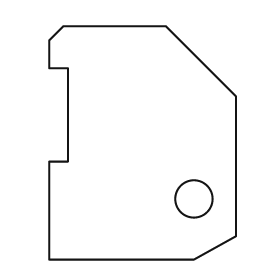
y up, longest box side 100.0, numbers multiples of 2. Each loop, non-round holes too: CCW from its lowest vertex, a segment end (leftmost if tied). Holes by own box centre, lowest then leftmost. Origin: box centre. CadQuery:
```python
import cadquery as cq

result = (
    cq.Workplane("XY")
    .moveTo(-40.0, -50.0)
    .lineTo(22.0, -50.0)
    .lineTo(40.0, -40.0)
    .lineTo(40.0, 20.0)
    .lineTo(10.0, 50.0)
    .lineTo(-34.0, 50.0)
    .lineTo(-40.0, 44.0)
    .lineTo(-40.0, 32.0)
    .lineTo(-32.0, 32.0)
    .lineTo(-32.0, -8.0)
    .lineTo(-40.0, -8.0)
    .close()
    .moveTo(22.0, -24.0)
    .circle(8.0)
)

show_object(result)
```